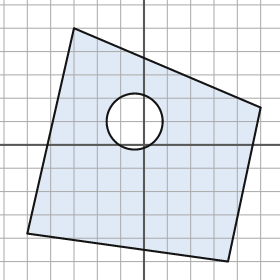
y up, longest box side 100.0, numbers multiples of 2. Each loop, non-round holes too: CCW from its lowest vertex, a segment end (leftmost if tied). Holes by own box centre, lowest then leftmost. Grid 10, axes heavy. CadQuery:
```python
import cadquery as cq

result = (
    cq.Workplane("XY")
    .moveTo(36.0, -50.0)
    .lineTo(50.0, 16.0)
    .lineTo(-30.0, 50.0)
    .lineTo(-50.0, -38.0)
    .close()
    .moveTo(-4.0, 10.0)
    .circle(12.0)
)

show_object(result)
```